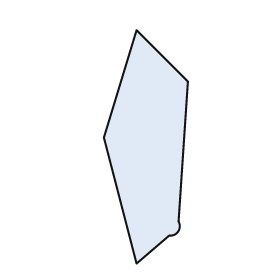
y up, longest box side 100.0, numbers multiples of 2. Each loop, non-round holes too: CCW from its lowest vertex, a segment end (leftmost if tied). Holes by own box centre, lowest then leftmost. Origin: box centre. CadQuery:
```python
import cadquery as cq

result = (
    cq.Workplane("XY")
    .moveTo(-4.0, -50.0)
    .lineTo(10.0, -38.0)
    .threePointArc((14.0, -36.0), (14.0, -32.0))
    .lineTo(18.0, 28.0)
    .lineTo(-4.0, 50.0)
    .lineTo(-18.0, 4.0)
    .close()
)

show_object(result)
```